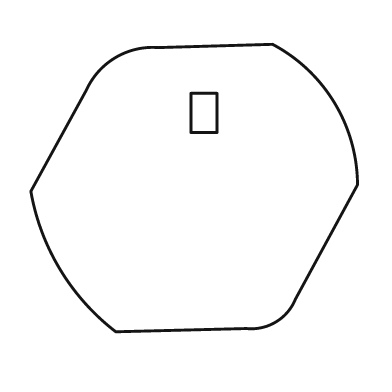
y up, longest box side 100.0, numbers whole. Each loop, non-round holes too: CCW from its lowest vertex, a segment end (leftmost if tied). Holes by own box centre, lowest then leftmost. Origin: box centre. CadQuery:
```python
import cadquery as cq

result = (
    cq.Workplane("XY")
    .moveTo(-24.0, -44.0)
    .lineTo(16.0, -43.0)
    .threePointArc((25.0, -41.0), (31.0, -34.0))
    .lineTo(50.0, 1.0)
    .threePointArc((43.0, 26.0), (24.0, 44.0))
    .lineTo(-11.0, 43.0)
    .threePointArc((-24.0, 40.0), (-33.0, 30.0))
    .lineTo(-50.0, -1.0)
    .threePointArc((-41.0, -25.0), (-24.0, -44.0))
    .close()
    .moveTo(-1.0, 17.0)
    .lineTo(7.0, 17.0)
    .lineTo(7.0, 29.0)
    .lineTo(-1.0, 29.0)
    .close()
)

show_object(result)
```